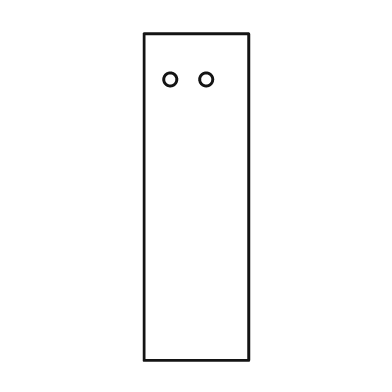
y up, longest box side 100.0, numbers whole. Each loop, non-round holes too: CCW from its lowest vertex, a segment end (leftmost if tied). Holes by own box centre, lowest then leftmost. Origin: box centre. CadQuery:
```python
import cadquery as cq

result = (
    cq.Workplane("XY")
    .moveTo(-16.0, -50.0)
    .lineTo(16.0, -50.0)
    .lineTo(16.0, 50.0)
    .lineTo(-16.0, 50.0)
    .close()
    .moveTo(-8.0, 36.0)
    .circle(2.0)
    .moveTo(3.0, 36.0)
    .circle(2.0)
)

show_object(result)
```